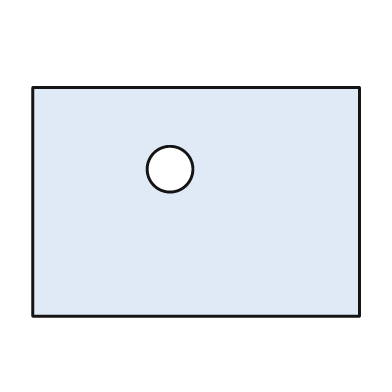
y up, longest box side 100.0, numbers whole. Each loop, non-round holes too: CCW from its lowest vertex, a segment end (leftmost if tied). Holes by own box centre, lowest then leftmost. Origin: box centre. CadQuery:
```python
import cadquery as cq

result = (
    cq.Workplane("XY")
    .moveTo(-50.0, -35.0)
    .lineTo(50.0, -35.0)
    .lineTo(50.0, 35.0)
    .lineTo(-50.0, 35.0)
    .close()
    .moveTo(-8.0, 10.0)
    .circle(7.0)
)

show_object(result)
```